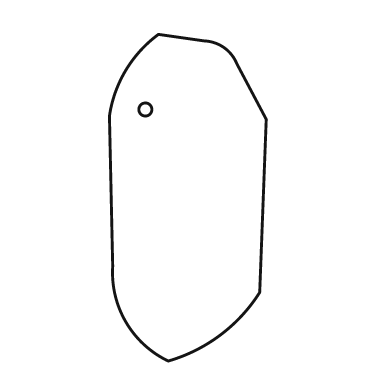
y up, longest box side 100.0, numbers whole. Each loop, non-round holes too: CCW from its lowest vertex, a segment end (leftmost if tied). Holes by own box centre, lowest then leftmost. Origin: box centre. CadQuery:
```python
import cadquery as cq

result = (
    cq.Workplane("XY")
    .moveTo(-6.0, -50.0)
    .threePointArc((10.0, -42.0), (22.0, -29.0))
    .lineTo(24.0, 24.0)
    .lineTo(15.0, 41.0)
    .threePointArc((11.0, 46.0), (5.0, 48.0))
    .lineTo(-9.0, 50.0)
    .threePointArc((-19.0, 39.0), (-24.0, 25.0))
    .lineTo(-23.0, -21.0)
    .threePointArc((-19.0, -38.0), (-6.0, -50.0))
    .close()
    .moveTo(-13.0, 27.0)
    .circle(2.0)
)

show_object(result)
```